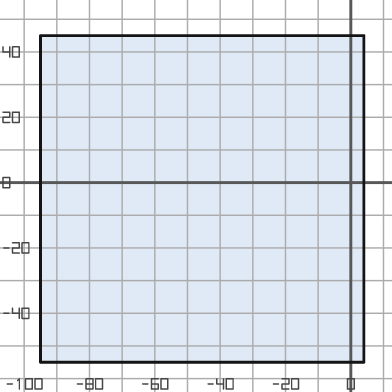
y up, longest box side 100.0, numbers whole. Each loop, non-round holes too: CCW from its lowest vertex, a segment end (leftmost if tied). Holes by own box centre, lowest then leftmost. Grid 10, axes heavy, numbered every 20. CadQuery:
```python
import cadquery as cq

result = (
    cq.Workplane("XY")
    .moveTo(-95.0, -55.0)
    .lineTo(4.0, -55.0)
    .lineTo(4.0, 45.0)
    .lineTo(-95.0, 45.0)
    .close()
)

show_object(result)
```